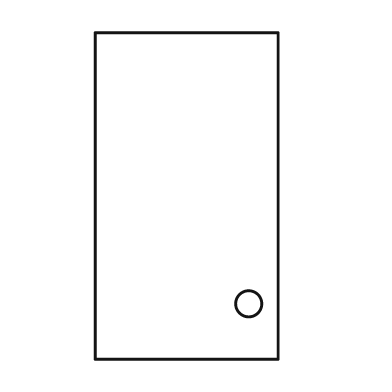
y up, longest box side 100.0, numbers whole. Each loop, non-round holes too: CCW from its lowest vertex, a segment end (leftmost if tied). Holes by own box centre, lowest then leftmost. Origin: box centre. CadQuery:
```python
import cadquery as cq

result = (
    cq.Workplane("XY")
    .moveTo(-28.0, -50.0)
    .lineTo(28.0, -50.0)
    .lineTo(28.0, 50.0)
    .lineTo(-28.0, 50.0)
    .close()
    .moveTo(19.0, -33.0)
    .circle(4.0)
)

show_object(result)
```